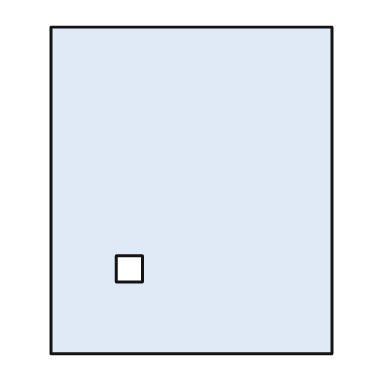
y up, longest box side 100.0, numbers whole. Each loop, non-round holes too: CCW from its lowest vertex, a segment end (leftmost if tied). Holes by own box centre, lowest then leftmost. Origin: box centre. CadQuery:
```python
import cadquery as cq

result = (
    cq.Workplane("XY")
    .moveTo(-43.0, -50.0)
    .lineTo(43.0, -50.0)
    .lineTo(43.0, 50.0)
    .lineTo(-43.0, 50.0)
    .close()
    .moveTo(-23.0, -28.0)
    .lineTo(-15.0, -28.0)
    .lineTo(-15.0, -20.0)
    .lineTo(-23.0, -20.0)
    .close()
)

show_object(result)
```